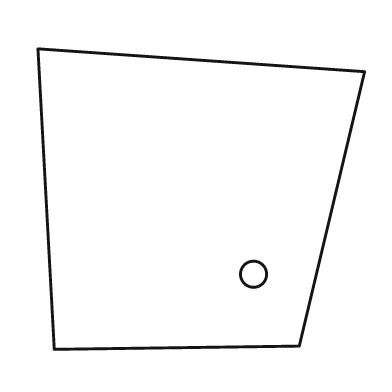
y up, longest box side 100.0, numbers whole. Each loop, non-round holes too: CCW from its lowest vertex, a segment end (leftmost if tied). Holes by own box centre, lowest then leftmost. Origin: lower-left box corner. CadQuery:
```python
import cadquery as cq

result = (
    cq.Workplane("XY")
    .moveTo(5.0, 0.0)
    .lineTo(80.0, 1.0)
    .lineTo(100.0, 85.0)
    .lineTo(0.0, 92.0)
    .close()
    .moveTo(66.0, 23.0)
    .circle(4.0)
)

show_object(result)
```